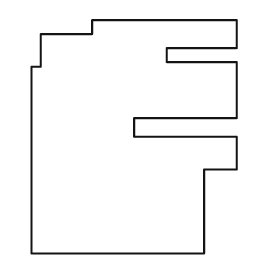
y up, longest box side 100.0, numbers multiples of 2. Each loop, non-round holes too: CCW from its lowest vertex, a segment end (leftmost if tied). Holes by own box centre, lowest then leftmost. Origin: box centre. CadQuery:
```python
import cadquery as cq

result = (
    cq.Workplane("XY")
    .moveTo(-44.0, -50.0)
    .lineTo(30.0, -50.0)
    .lineTo(30.0, -14.0)
    .lineTo(44.0, -14.0)
    .lineTo(44.0, 0.0)
    .lineTo(0.0, 0.0)
    .lineTo(0.0, 8.0)
    .lineTo(44.0, 8.0)
    .lineTo(44.0, 32.0)
    .lineTo(14.0, 32.0)
    .lineTo(14.0, 38.0)
    .lineTo(44.0, 38.0)
    .lineTo(44.0, 50.0)
    .lineTo(-18.0, 50.0)
    .lineTo(-18.0, 44.0)
    .lineTo(-40.0, 44.0)
    .lineTo(-40.0, 30.0)
    .lineTo(-44.0, 30.0)
    .close()
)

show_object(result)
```